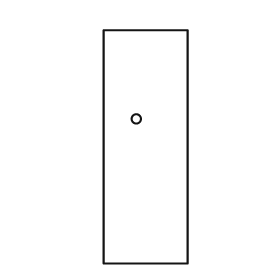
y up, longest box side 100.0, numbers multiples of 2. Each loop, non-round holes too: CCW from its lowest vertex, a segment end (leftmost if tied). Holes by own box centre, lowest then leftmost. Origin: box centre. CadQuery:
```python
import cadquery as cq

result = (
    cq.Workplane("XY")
    .moveTo(-18.0, -50.0)
    .lineTo(18.0, -50.0)
    .lineTo(18.0, 50.0)
    .lineTo(-18.0, 50.0)
    .close()
    .moveTo(-4.0, 12.0)
    .circle(2.0)
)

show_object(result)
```